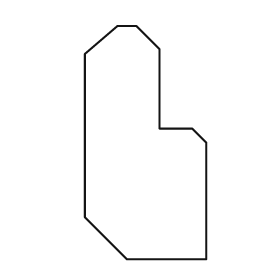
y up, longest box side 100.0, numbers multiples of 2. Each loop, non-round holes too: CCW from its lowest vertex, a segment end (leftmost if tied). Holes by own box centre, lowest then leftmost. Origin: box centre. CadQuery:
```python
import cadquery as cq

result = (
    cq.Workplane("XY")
    .moveTo(-8.0, -50.0)
    .lineTo(26.0, -50.0)
    .lineTo(26.0, 0.0)
    .lineTo(20.0, 6.0)
    .lineTo(6.0, 6.0)
    .lineTo(6.0, 40.0)
    .lineTo(-4.0, 50.0)
    .lineTo(-12.0, 50.0)
    .lineTo(-26.0, 38.0)
    .lineTo(-26.0, -32.0)
    .close()
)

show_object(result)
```